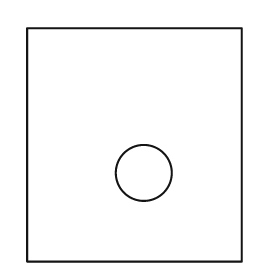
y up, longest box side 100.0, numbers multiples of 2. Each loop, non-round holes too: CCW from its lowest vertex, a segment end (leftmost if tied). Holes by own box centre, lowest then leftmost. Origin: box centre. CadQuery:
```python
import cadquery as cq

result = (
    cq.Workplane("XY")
    .moveTo(-46.0, -50.0)
    .lineTo(46.0, -50.0)
    .lineTo(46.0, 50.0)
    .lineTo(-46.0, 50.0)
    .close()
    .moveTo(4.0, -12.0)
    .circle(12.0)
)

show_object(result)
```